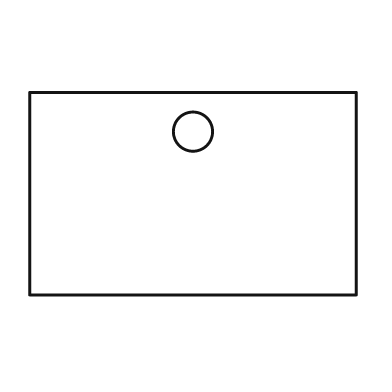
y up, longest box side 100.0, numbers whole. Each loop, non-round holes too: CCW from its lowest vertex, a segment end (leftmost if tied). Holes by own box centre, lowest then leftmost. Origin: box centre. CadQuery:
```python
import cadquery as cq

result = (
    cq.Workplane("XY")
    .moveTo(-50.0, -31.0)
    .lineTo(50.0, -31.0)
    .lineTo(50.0, 31.0)
    .lineTo(-50.0, 31.0)
    .close()
    .moveTo(0.0, 19.0)
    .circle(6.0)
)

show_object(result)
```